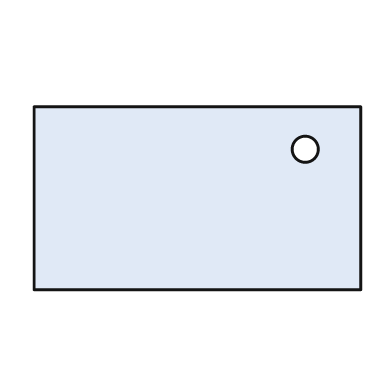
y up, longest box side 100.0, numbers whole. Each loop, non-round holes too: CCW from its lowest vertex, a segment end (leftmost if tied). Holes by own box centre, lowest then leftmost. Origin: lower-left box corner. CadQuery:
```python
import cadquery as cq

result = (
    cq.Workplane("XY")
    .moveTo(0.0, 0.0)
    .lineTo(100.0, 0.0)
    .lineTo(100.0, 56.0)
    .lineTo(0.0, 56.0)
    .close()
    .moveTo(83.0, 43.0)
    .circle(4.0)
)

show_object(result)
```